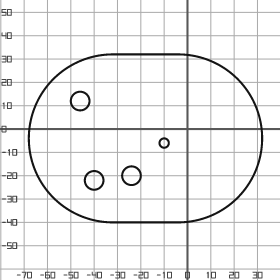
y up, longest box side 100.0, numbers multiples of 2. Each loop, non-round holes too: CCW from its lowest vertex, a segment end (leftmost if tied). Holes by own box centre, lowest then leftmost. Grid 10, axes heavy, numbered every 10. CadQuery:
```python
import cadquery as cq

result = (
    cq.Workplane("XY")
    .moveTo(-32.0, -40.0)
    .lineTo(-4.0, -40.0)
    .threePointArc((32.0, -4.0), (-4.0, 32.0))
    .lineTo(-32.0, 32.0)
    .threePointArc((-68.0, -4.0), (-32.0, -40.0))
    .close()
    .moveTo(-40.0, -22.0)
    .circle(4.0)
    .moveTo(-24.0, -20.0)
    .circle(4.0)
    .moveTo(-10.0, -6.0)
    .circle(2.0)
    .moveTo(-46.0, 12.0)
    .circle(4.0)
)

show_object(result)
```